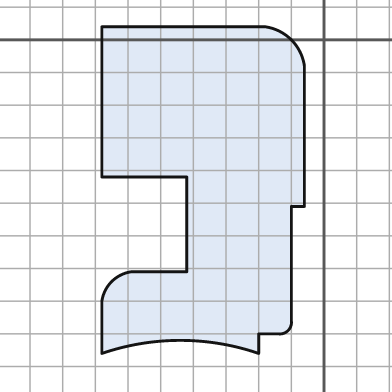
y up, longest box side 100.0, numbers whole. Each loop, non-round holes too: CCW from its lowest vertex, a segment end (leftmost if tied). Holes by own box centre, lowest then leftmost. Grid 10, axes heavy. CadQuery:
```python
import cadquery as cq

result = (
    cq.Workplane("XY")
    .moveTo(-68.0, -96.0)
    .threePointArc((-44.0, -92.0), (-20.0, -96.0))
    .lineTo(-20.0, -90.0)
    .lineTo(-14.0, -90.0)
    .threePointArc((-11.0, -89.0), (-10.0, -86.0))
    .lineTo(-10.0, -51.0)
    .lineTo(-6.0, -51.0)
    .lineTo(-6.0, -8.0)
    .threePointArc((-10.0, 0.0), (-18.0, 4.0))
    .lineTo(-68.0, 4.0)
    .lineTo(-68.0, -42.0)
    .lineTo(-42.0, -42.0)
    .lineTo(-42.0, -71.0)
    .lineTo(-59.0, -71.0)
    .threePointArc((-65.0, -74.0), (-68.0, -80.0))
    .close()
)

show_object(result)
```